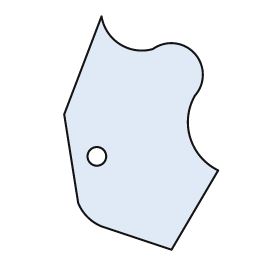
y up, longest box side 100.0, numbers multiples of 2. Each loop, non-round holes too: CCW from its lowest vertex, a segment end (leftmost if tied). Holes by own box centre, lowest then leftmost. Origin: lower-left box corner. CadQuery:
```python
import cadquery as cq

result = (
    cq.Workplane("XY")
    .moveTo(46.0, 0.0)
    .lineTo(66.0, 34.0)
    .threePointArc((54.0, 48.0), (56.0, 66.0))
    .threePointArc((56.0, 84.0), (38.0, 86.0))
    .threePointArc((24.0, 88.0), (16.0, 100.0))
    .lineTo(0.0, 58.0)
    .lineTo(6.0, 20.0)
    .threePointArc((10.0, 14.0), (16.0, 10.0))
    .close()
    .moveTo(14.0, 40.0)
    .circle(4.0)
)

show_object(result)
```